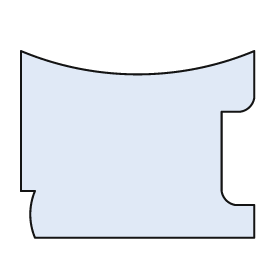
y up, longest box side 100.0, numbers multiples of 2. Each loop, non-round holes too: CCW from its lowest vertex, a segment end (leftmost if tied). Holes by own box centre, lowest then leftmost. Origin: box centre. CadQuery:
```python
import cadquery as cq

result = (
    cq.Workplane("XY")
    .moveTo(-44.0, -40.0)
    .lineTo(50.0, -40.0)
    .lineTo(50.0, -26.0)
    .lineTo(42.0, -26.0)
    .threePointArc((38.0, -24.0), (36.0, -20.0))
    .lineTo(36.0, 14.0)
    .lineTo(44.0, 14.0)
    .threePointArc((48.0, 16.0), (50.0, 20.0))
    .lineTo(50.0, 40.0)
    .threePointArc((0.0, 30.0), (-50.0, 40.0))
    .lineTo(-50.0, -20.0)
    .lineTo(-44.0, -20.0)
    .threePointArc((-46.0, -30.0), (-44.0, -40.0))
    .close()
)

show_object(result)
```